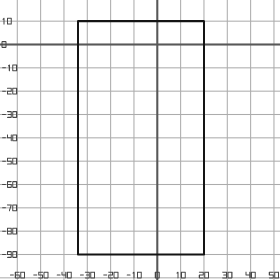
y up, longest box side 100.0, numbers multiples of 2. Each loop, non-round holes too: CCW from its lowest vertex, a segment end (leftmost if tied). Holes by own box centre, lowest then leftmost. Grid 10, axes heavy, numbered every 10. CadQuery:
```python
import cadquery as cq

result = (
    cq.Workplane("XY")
    .moveTo(-34.0, -90.0)
    .lineTo(20.0, -90.0)
    .lineTo(20.0, 10.0)
    .lineTo(-34.0, 10.0)
    .close()
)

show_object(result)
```